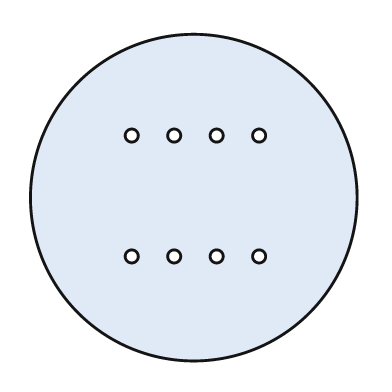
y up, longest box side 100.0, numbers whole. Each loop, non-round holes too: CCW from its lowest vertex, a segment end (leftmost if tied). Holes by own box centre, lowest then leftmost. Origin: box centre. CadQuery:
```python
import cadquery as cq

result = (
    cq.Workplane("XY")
    .moveTo(0.0, 0.0)
    .circle(50.0)
    .moveTo(-19.0, -18.0)
    .circle(2.0)
    .moveTo(-6.0, -18.0)
    .circle(2.0)
    .moveTo(7.0, -18.0)
    .circle(2.0)
    .moveTo(20.0, -18.0)
    .circle(2.0)
    .moveTo(-19.0, 19.0)
    .circle(2.0)
    .moveTo(-6.0, 19.0)
    .circle(2.0)
    .moveTo(7.0, 19.0)
    .circle(2.0)
    .moveTo(20.0, 19.0)
    .circle(2.0)
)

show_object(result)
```